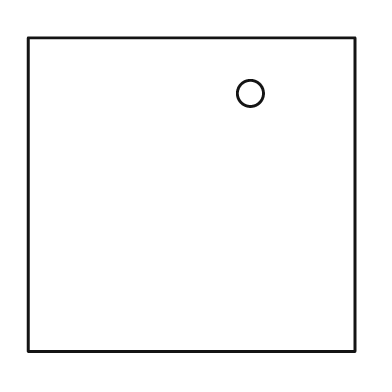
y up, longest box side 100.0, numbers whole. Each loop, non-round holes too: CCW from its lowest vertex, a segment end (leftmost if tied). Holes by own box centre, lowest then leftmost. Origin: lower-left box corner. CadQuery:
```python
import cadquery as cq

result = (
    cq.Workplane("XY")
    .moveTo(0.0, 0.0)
    .lineTo(100.0, 0.0)
    .lineTo(100.0, 96.0)
    .lineTo(0.0, 96.0)
    .close()
    .moveTo(68.0, 79.0)
    .circle(4.0)
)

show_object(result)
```